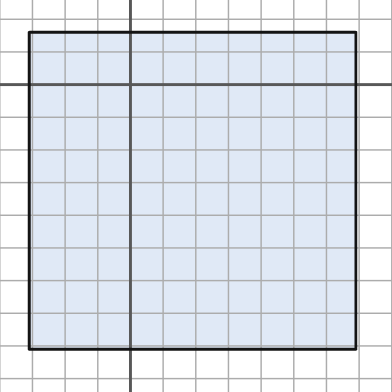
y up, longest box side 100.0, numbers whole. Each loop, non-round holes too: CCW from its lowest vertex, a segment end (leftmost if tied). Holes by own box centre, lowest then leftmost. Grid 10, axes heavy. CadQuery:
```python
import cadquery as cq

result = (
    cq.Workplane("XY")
    .moveTo(-31.0, -81.0)
    .lineTo(69.0, -81.0)
    .lineTo(69.0, 16.0)
    .lineTo(-31.0, 16.0)
    .close()
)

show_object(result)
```